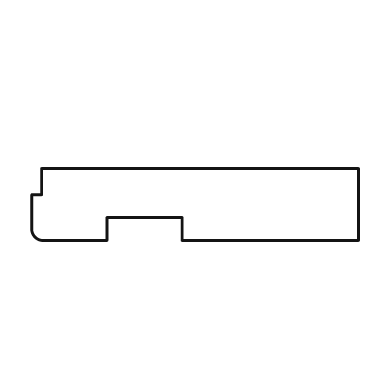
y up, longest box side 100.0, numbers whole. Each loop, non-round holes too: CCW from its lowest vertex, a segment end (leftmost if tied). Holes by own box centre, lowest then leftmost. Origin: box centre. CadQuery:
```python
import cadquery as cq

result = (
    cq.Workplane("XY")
    .moveTo(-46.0, -11.0)
    .lineTo(-27.0, -11.0)
    .lineTo(-27.0, -4.0)
    .lineTo(-4.0, -4.0)
    .lineTo(-4.0, -11.0)
    .lineTo(50.0, -11.0)
    .lineTo(50.0, 11.0)
    .lineTo(-47.0, 11.0)
    .lineTo(-47.0, 3.0)
    .lineTo(-50.0, 3.0)
    .lineTo(-50.0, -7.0)
    .threePointArc((-49.0, -10.0), (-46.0, -11.0))
    .close()
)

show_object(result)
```